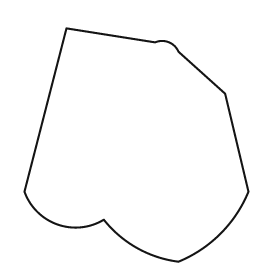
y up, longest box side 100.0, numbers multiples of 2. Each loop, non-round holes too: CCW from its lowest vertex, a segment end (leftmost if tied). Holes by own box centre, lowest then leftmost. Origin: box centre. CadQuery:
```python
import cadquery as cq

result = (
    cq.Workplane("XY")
    .moveTo(18.0, -50.0)
    .threePointArc((36.0, -38.0), (48.0, -20.0))
    .lineTo(38.0, 22.0)
    .lineTo(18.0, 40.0)
    .threePointArc((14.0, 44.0), (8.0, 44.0))
    .lineTo(-30.0, 50.0)
    .lineTo(-48.0, -20.0)
    .threePointArc((-34.0, -34.0), (-14.0, -32.0))
    .threePointArc((0.0, -44.0), (18.0, -50.0))
    .close()
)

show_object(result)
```